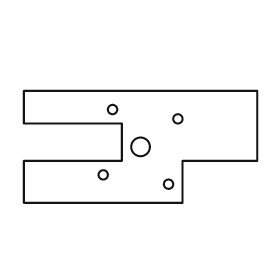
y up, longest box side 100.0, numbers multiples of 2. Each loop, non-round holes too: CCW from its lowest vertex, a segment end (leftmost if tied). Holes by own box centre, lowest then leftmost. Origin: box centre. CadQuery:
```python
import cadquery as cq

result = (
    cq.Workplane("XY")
    .moveTo(-50.0, -24.0)
    .lineTo(18.0, -24.0)
    .lineTo(18.0, -6.0)
    .lineTo(50.0, -6.0)
    .lineTo(50.0, 24.0)
    .lineTo(-50.0, 24.0)
    .lineTo(-50.0, 10.0)
    .lineTo(-8.0, 10.0)
    .lineTo(-8.0, -6.0)
    .lineTo(-50.0, -6.0)
    .close()
    .moveTo(12.0, -16.0)
    .circle(2.0)
    .moveTo(-16.0, -12.0)
    .circle(2.0)
    .moveTo(0.0, 0.0)
    .circle(4.0)
    .moveTo(16.0, 12.0)
    .circle(2.0)
    .moveTo(-12.0, 16.0)
    .circle(2.0)
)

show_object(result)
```